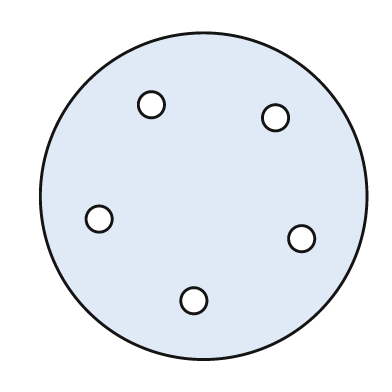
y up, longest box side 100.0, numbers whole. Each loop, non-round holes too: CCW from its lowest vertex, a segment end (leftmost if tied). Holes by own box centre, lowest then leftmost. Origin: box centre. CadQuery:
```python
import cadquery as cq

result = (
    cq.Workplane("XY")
    .moveTo(0.0, 0.0)
    .circle(50.0)
    .moveTo(-3.0, -32.0)
    .circle(4.0)
    .moveTo(30.0, -13.0)
    .circle(4.0)
    .moveTo(-32.0, -7.0)
    .circle(4.0)
    .moveTo(22.0, 24.0)
    .circle(4.0)
    .moveTo(-16.0, 28.0)
    .circle(4.0)
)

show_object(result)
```